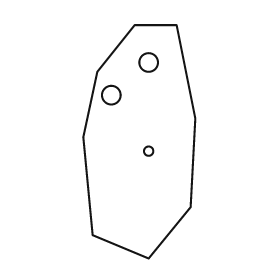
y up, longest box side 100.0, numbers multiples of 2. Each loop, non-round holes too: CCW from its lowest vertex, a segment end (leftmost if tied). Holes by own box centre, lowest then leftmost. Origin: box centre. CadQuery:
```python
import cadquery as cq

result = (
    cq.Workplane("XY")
    .moveTo(4.0, -50.0)
    .lineTo(22.0, -28.0)
    .lineTo(24.0, 10.0)
    .lineTo(16.0, 50.0)
    .lineTo(-2.0, 50.0)
    .lineTo(-18.0, 30.0)
    .lineTo(-24.0, 2.0)
    .lineTo(-20.0, -40.0)
    .close()
    .moveTo(4.0, -4.0)
    .circle(2.0)
    .moveTo(-12.0, 20.0)
    .circle(4.0)
    .moveTo(4.0, 34.0)
    .circle(4.0)
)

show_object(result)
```